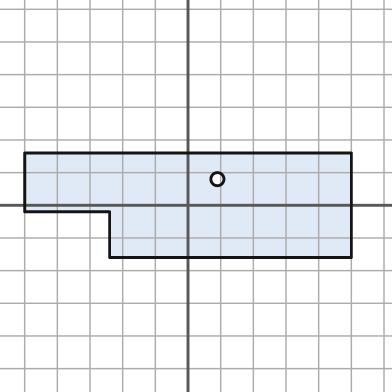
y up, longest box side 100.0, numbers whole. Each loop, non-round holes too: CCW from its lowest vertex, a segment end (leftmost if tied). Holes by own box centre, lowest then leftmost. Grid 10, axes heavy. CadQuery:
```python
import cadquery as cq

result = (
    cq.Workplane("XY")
    .moveTo(-24.0, -16.0)
    .lineTo(50.0, -16.0)
    .lineTo(50.0, 16.0)
    .lineTo(-50.0, 16.0)
    .lineTo(-50.0, -2.0)
    .lineTo(-24.0, -2.0)
    .close()
    .moveTo(9.0, 8.0)
    .circle(2.0)
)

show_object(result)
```